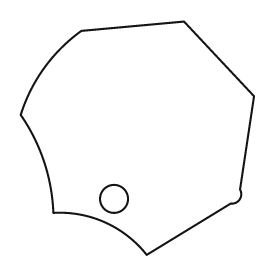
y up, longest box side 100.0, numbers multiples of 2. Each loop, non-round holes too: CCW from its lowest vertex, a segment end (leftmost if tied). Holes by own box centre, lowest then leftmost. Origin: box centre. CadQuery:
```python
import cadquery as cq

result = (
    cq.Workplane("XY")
    .moveTo(4.0, -50.0)
    .lineTo(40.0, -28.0)
    .threePointArc((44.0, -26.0), (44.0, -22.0))
    .lineTo(50.0, 18.0)
    .lineTo(20.0, 50.0)
    .lineTo(-24.0, 46.0)
    .threePointArc((-40.0, 30.0), (-50.0, 10.0))
    .threePointArc((-40.0, -10.0), (-36.0, -32.0))
    .threePointArc((-14.0, -36.0), (4.0, -50.0))
    .close()
    .moveTo(-10.0, -26.0)
    .circle(6.0)
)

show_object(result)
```